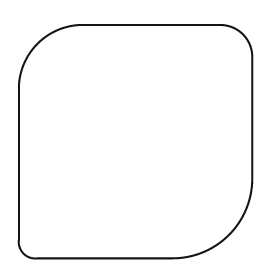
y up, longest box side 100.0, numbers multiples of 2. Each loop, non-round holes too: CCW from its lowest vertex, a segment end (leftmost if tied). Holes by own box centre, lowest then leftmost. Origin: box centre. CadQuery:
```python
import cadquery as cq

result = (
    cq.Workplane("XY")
    .moveTo(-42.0, -50.0)
    .lineTo(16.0, -50.0)
    .threePointArc((40.0, -40.0), (50.0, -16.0))
    .lineTo(50.0, 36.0)
    .threePointArc((46.0, 46.0), (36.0, 50.0))
    .lineTo(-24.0, 50.0)
    .threePointArc((-42.0, 42.0), (-50.0, 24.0))
    .lineTo(-50.0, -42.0)
    .threePointArc((-48.0, -48.0), (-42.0, -50.0))
    .close()
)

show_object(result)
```